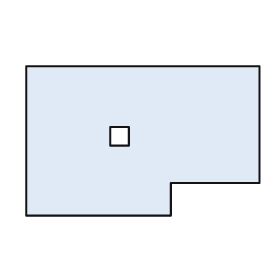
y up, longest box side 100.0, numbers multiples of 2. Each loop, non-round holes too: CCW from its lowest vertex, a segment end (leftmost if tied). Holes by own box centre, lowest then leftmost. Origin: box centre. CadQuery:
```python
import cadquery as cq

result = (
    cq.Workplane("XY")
    .moveTo(-50.0, -32.0)
    .lineTo(12.0, -32.0)
    .lineTo(12.0, -18.0)
    .lineTo(50.0, -18.0)
    .lineTo(50.0, 32.0)
    .lineTo(-50.0, 32.0)
    .close()
    .moveTo(-14.0, -2.0)
    .lineTo(-6.0, -2.0)
    .lineTo(-6.0, 6.0)
    .lineTo(-14.0, 6.0)
    .close()
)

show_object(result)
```